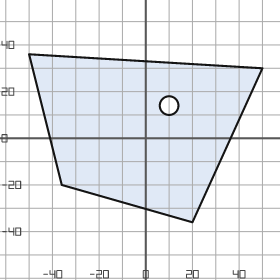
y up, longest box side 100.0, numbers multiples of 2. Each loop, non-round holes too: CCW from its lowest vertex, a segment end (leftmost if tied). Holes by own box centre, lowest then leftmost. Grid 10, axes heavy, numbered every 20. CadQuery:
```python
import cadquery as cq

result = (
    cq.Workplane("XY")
    .moveTo(20.0, -36.0)
    .lineTo(50.0, 30.0)
    .lineTo(-50.0, 36.0)
    .lineTo(-36.0, -20.0)
    .close()
    .moveTo(10.0, 14.0)
    .circle(4.0)
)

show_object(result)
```